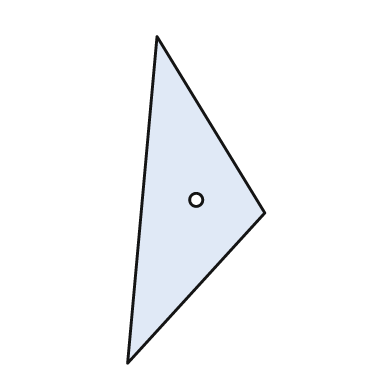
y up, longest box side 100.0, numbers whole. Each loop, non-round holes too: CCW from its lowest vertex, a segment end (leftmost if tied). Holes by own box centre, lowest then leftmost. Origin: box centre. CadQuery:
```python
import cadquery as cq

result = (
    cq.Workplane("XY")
    .moveTo(-21.0, -50.0)
    .lineTo(21.0, -4.0)
    .lineTo(-12.0, 50.0)
    .close()
    .moveTo(0.0, 0.0)
    .circle(2.0)
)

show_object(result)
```